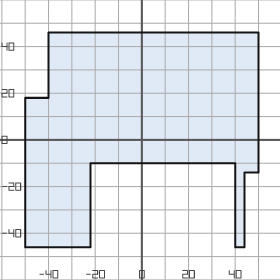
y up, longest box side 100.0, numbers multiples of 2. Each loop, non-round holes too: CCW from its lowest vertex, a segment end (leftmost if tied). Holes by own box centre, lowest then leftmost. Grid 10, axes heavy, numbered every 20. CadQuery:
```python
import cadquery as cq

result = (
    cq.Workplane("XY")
    .moveTo(-50.0, -46.0)
    .lineTo(-22.0, -46.0)
    .lineTo(-22.0, -10.0)
    .lineTo(40.0, -10.0)
    .lineTo(40.0, -46.0)
    .lineTo(44.0, -46.0)
    .lineTo(44.0, -14.0)
    .lineTo(50.0, -14.0)
    .lineTo(50.0, 46.0)
    .lineTo(-40.0, 46.0)
    .lineTo(-40.0, 18.0)
    .lineTo(-50.0, 18.0)
    .close()
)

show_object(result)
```